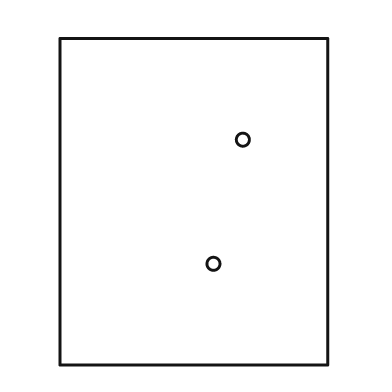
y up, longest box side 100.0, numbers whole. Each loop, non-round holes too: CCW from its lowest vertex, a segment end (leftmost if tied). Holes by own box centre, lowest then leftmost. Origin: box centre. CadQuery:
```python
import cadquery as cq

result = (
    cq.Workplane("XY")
    .moveTo(-41.0, -50.0)
    .lineTo(41.0, -50.0)
    .lineTo(41.0, 50.0)
    .lineTo(-41.0, 50.0)
    .close()
    .moveTo(6.0, -19.0)
    .circle(2.0)
    .moveTo(15.0, 19.0)
    .circle(2.0)
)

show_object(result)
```